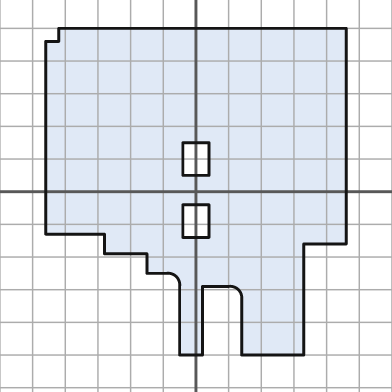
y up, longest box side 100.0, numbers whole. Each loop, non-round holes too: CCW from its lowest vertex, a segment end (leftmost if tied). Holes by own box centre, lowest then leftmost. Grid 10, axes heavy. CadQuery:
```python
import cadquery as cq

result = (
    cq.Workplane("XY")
    .moveTo(-5.0, -50.0)
    .lineTo(2.0, -50.0)
    .lineTo(2.0, -29.0)
    .lineTo(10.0, -29.0)
    .threePointArc((13.0, -30.0), (14.0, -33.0))
    .lineTo(14.0, -50.0)
    .lineTo(33.0, -50.0)
    .lineTo(33.0, -16.0)
    .lineTo(46.0, -16.0)
    .lineTo(46.0, 50.0)
    .lineTo(-42.0, 50.0)
    .lineTo(-42.0, 46.0)
    .lineTo(-46.0, 46.0)
    .lineTo(-46.0, -13.0)
    .lineTo(-28.0, -13.0)
    .lineTo(-28.0, -19.0)
    .lineTo(-15.0, -19.0)
    .lineTo(-15.0, -25.0)
    .lineTo(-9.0, -25.0)
    .threePointArc((-6.0, -26.0), (-5.0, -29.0))
    .close()
    .moveTo(-4.0, -14.0)
    .lineTo(4.0, -14.0)
    .lineTo(4.0, -4.0)
    .lineTo(-4.0, -4.0)
    .close()
    .moveTo(-4.0, 5.0)
    .lineTo(4.0, 5.0)
    .lineTo(4.0, 15.0)
    .lineTo(-4.0, 15.0)
    .close()
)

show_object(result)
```